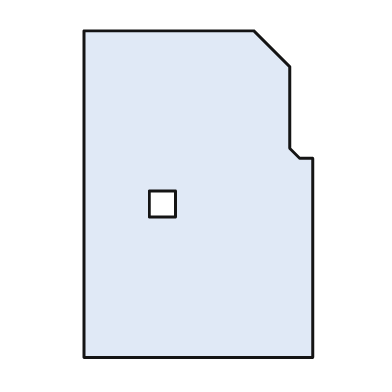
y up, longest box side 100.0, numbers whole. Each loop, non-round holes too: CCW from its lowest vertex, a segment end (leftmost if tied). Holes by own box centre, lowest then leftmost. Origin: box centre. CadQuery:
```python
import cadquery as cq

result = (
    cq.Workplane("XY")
    .moveTo(-35.0, -50.0)
    .lineTo(35.0, -50.0)
    .lineTo(35.0, 11.0)
    .lineTo(31.0, 11.0)
    .lineTo(28.0, 14.0)
    .lineTo(28.0, 39.0)
    .lineTo(17.0, 50.0)
    .lineTo(-35.0, 50.0)
    .close()
    .moveTo(-15.0, -7.0)
    .lineTo(-7.0, -7.0)
    .lineTo(-7.0, 1.0)
    .lineTo(-15.0, 1.0)
    .close()
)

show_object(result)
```